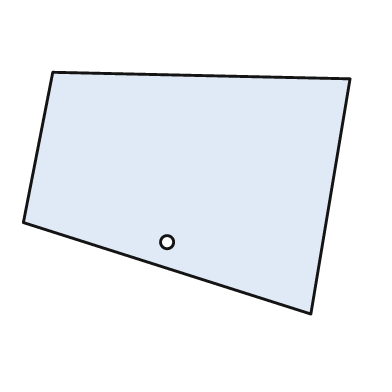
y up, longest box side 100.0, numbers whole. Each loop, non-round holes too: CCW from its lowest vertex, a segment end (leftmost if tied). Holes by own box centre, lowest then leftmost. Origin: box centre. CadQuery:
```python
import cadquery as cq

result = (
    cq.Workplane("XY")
    .moveTo(38.0, -37.0)
    .lineTo(50.0, 35.0)
    .lineTo(-41.0, 37.0)
    .lineTo(-50.0, -9.0)
    .close()
    .moveTo(-6.0, -15.0)
    .circle(2.0)
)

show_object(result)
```